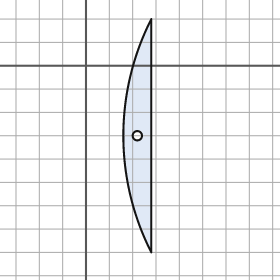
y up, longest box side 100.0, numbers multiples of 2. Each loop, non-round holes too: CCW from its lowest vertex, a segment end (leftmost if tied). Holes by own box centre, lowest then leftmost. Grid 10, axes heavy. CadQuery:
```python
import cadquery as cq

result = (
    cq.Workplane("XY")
    .moveTo(28.0, -80.0)
    .lineTo(28.0, 20.0)
    .threePointArc((16.0, -30.0), (28.0, -80.0))
    .close()
    .moveTo(22.0, -30.0)
    .circle(2.0)
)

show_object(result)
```